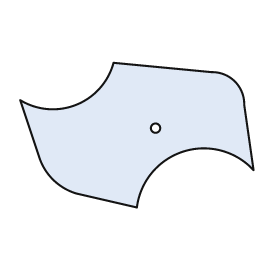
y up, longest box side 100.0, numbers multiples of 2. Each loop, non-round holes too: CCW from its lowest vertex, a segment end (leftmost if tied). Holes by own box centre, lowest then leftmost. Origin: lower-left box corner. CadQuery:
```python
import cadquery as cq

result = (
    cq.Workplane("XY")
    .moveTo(50.0, 0.0)
    .threePointArc((70.0, 24.0), (100.0, 16.0))
    .lineTo(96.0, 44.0)
    .threePointArc((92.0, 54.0), (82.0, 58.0))
    .lineTo(40.0, 62.0)
    .threePointArc((24.0, 44.0), (0.0, 46.0))
    .lineTo(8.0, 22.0)
    .threePointArc((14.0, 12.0), (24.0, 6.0))
    .close()
    .moveTo(58.0, 34.0)
    .circle(2.0)
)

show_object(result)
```